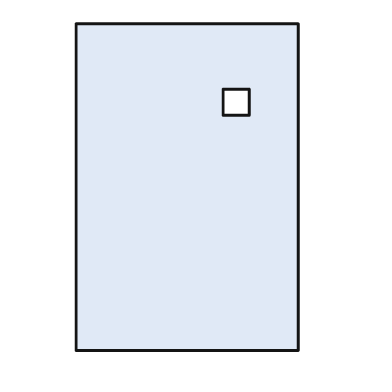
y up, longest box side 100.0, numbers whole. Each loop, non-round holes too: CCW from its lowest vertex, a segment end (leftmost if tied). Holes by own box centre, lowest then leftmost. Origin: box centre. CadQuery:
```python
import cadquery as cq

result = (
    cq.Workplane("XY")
    .moveTo(-34.0, -50.0)
    .lineTo(34.0, -50.0)
    .lineTo(34.0, 50.0)
    .lineTo(-34.0, 50.0)
    .close()
    .moveTo(11.0, 22.0)
    .lineTo(19.0, 22.0)
    .lineTo(19.0, 30.0)
    .lineTo(11.0, 30.0)
    .close()
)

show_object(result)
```